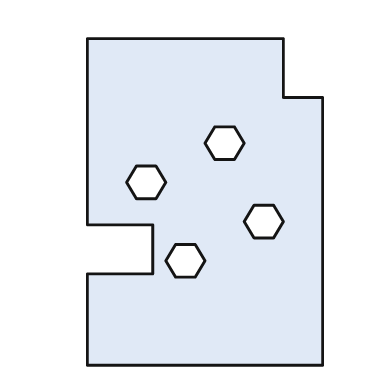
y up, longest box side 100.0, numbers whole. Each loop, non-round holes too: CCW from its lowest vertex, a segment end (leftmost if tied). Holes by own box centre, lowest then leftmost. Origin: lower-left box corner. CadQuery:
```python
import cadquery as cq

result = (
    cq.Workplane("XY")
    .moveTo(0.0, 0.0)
    .lineTo(72.0, 0.0)
    .lineTo(72.0, 82.0)
    .lineTo(60.0, 82.0)
    .lineTo(60.0, 100.0)
    .lineTo(0.0, 100.0)
    .lineTo(0.0, 43.0)
    .lineTo(20.0, 43.0)
    .lineTo(20.0, 28.0)
    .lineTo(0.0, 28.0)
    .close()
    .moveTo(27.0, 27.0)
    .lineTo(33.0, 27.0)
    .lineTo(36.0, 32.0)
    .lineTo(33.0, 37.0)
    .lineTo(27.0, 37.0)
    .lineTo(24.0, 32.0)
    .close()
    .moveTo(51.0, 39.0)
    .lineTo(57.0, 39.0)
    .lineTo(60.0, 44.0)
    .lineTo(57.0, 49.0)
    .lineTo(51.0, 49.0)
    .lineTo(48.0, 44.0)
    .close()
    .moveTo(15.0, 51.0)
    .lineTo(21.0, 51.0)
    .lineTo(24.0, 56.0)
    .lineTo(21.0, 61.0)
    .lineTo(15.0, 61.0)
    .lineTo(12.0, 56.0)
    .close()
    .moveTo(39.0, 63.0)
    .lineTo(45.0, 63.0)
    .lineTo(48.0, 68.0)
    .lineTo(45.0, 73.0)
    .lineTo(39.0, 73.0)
    .lineTo(36.0, 68.0)
    .close()
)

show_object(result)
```